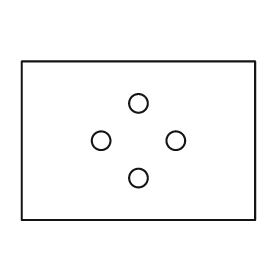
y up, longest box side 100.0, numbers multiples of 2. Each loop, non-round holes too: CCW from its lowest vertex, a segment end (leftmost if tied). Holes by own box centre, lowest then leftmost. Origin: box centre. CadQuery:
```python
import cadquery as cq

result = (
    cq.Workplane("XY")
    .moveTo(-50.0, -34.0)
    .lineTo(50.0, -34.0)
    .lineTo(50.0, 34.0)
    .lineTo(-50.0, 34.0)
    .close()
    .moveTo(0.0, -16.0)
    .circle(4.0)
    .moveTo(-16.0, 0.0)
    .circle(4.0)
    .moveTo(16.0, 0.0)
    .circle(4.0)
    .moveTo(0.0, 16.0)
    .circle(4.0)
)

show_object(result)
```